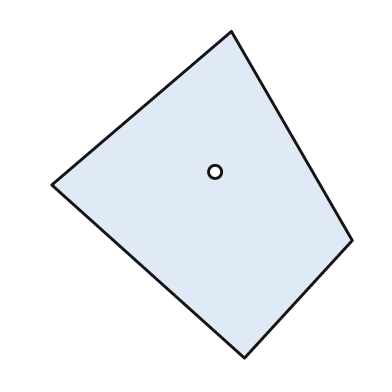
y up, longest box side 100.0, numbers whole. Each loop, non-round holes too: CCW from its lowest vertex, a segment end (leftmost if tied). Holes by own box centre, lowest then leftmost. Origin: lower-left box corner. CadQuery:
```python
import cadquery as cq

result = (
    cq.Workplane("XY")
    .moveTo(59.0, 0.0)
    .lineTo(92.0, 36.0)
    .lineTo(55.0, 100.0)
    .lineTo(0.0, 53.0)
    .close()
    .moveTo(50.0, 57.0)
    .circle(2.0)
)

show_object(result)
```